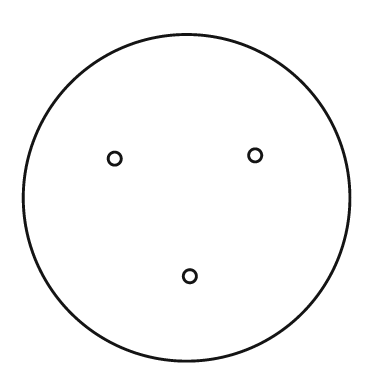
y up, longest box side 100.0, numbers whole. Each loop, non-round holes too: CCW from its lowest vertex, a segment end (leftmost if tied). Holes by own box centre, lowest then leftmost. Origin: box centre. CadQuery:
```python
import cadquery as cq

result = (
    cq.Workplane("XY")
    .moveTo(0.0, 0.0)
    .circle(50.0)
    .moveTo(1.0, -24.0)
    .circle(2.0)
    .moveTo(-22.0, 12.0)
    .circle(2.0)
    .moveTo(21.0, 13.0)
    .circle(2.0)
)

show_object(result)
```